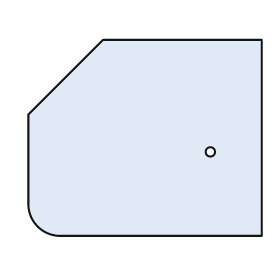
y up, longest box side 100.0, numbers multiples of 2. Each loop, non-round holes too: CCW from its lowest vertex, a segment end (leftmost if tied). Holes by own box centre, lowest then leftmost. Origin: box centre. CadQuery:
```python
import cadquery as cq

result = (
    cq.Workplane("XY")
    .moveTo(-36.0, -42.0)
    .lineTo(50.0, -42.0)
    .lineTo(50.0, 42.0)
    .lineTo(-18.0, 42.0)
    .lineTo(-50.0, 10.0)
    .lineTo(-50.0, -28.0)
    .threePointArc((-46.0, -38.0), (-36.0, -42.0))
    .close()
    .moveTo(28.0, -6.0)
    .circle(2.0)
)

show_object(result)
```